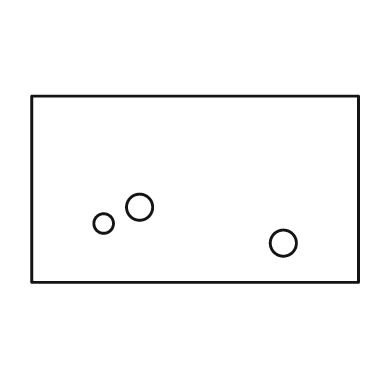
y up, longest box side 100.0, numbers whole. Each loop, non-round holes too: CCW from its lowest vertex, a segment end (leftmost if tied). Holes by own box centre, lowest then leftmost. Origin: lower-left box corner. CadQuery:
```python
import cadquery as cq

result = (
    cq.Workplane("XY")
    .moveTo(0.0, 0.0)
    .lineTo(100.0, 0.0)
    .lineTo(100.0, 57.0)
    .lineTo(0.0, 57.0)
    .close()
    .moveTo(77.0, 12.0)
    .circle(4.0)
    .moveTo(22.0, 18.0)
    .circle(3.0)
    .moveTo(33.0, 23.0)
    .circle(4.0)
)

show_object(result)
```